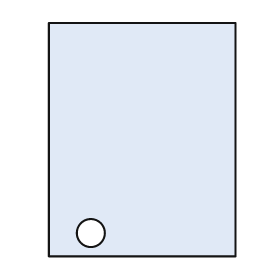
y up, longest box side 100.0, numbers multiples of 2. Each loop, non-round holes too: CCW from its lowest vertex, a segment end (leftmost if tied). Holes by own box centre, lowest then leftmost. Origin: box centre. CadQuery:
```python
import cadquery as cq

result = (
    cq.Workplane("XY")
    .moveTo(-40.0, -50.0)
    .lineTo(40.0, -50.0)
    .lineTo(40.0, 50.0)
    .lineTo(-40.0, 50.0)
    .close()
    .moveTo(-22.0, -40.0)
    .circle(6.0)
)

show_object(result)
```